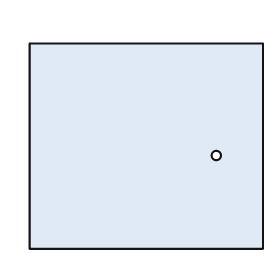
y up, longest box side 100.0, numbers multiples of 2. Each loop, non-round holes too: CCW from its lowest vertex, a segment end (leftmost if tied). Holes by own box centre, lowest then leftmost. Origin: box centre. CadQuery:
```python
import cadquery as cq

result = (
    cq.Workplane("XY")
    .moveTo(-50.0, -44.0)
    .lineTo(50.0, -44.0)
    .lineTo(50.0, 44.0)
    .lineTo(-50.0, 44.0)
    .close()
    .moveTo(30.0, -4.0)
    .circle(2.0)
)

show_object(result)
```